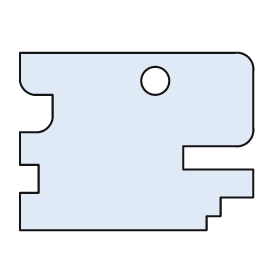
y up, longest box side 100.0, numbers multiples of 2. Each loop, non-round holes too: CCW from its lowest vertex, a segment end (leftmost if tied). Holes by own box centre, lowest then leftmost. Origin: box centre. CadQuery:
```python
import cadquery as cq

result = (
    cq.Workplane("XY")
    .moveTo(-50.0, -38.0)
    .lineTo(30.0, -38.0)
    .lineTo(30.0, -32.0)
    .lineTo(36.0, -32.0)
    .lineTo(36.0, -24.0)
    .lineTo(50.0, -24.0)
    .lineTo(50.0, -12.0)
    .lineTo(20.0, -12.0)
    .lineTo(20.0, -2.0)
    .lineTo(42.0, -2.0)
    .threePointArc((48.0, 0.0), (50.0, 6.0))
    .lineTo(50.0, 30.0)
    .threePointArc((48.0, 36.0), (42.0, 38.0))
    .lineTo(-50.0, 38.0)
    .lineTo(-50.0, 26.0)
    .threePointArc((-48.0, 22.0), (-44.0, 20.0))
    .lineTo(-36.0, 20.0)
    .lineTo(-36.0, 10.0)
    .threePointArc((-38.0, 6.0), (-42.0, 4.0))
    .lineTo(-50.0, 4.0)
    .lineTo(-50.0, -10.0)
    .lineTo(-42.0, -10.0)
    .lineTo(-42.0, -22.0)
    .lineTo(-50.0, -22.0)
    .close()
    .moveTo(8.0, 26.0)
    .circle(6.0)
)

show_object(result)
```